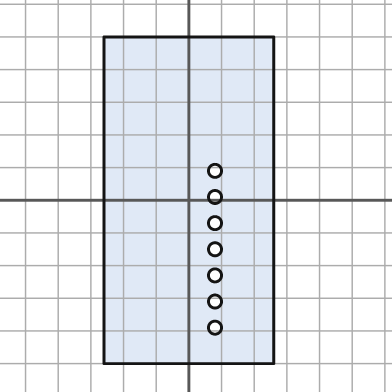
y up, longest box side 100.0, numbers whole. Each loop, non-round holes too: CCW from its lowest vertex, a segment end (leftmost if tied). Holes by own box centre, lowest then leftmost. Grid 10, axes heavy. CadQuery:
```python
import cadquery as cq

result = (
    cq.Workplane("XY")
    .moveTo(-26.0, -50.0)
    .lineTo(26.0, -50.0)
    .lineTo(26.0, 50.0)
    .lineTo(-26.0, 50.0)
    .close()
    .moveTo(8.0, -39.0)
    .circle(2.0)
    .moveTo(8.0, -31.0)
    .circle(2.0)
    .moveTo(8.0, -23.0)
    .circle(2.0)
    .moveTo(8.0, -15.0)
    .circle(2.0)
    .moveTo(8.0, -7.0)
    .circle(2.0)
    .moveTo(8.0, 1.0)
    .circle(2.0)
    .moveTo(8.0, 9.0)
    .circle(2.0)
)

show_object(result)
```